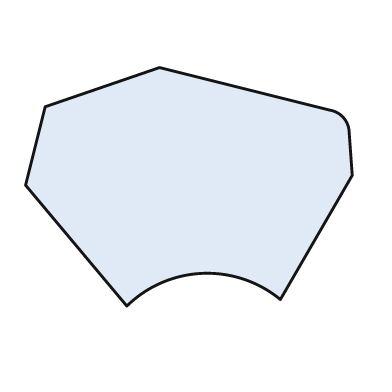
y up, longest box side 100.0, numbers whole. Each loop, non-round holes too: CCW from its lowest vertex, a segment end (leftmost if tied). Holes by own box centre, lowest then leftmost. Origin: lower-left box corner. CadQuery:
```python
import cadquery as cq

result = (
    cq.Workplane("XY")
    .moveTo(31.0, 0.0)
    .threePointArc((54.0, 10.0), (78.0, 2.0))
    .lineTo(100.0, 40.0)
    .lineTo(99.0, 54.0)
    .threePointArc((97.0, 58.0), (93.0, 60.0))
    .lineTo(41.0, 73.0)
    .lineTo(6.0, 61.0)
    .lineTo(0.0, 37.0)
    .close()
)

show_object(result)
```